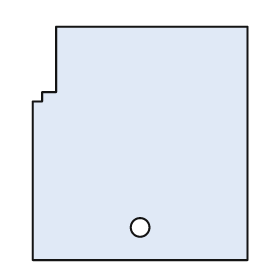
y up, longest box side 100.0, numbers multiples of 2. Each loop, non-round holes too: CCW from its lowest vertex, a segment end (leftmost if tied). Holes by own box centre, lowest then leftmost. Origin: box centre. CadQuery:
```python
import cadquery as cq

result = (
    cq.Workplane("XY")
    .moveTo(-46.0, -50.0)
    .lineTo(46.0, -50.0)
    .lineTo(46.0, 50.0)
    .lineTo(-36.0, 50.0)
    .lineTo(-36.0, 22.0)
    .lineTo(-42.0, 22.0)
    .lineTo(-42.0, 18.0)
    .lineTo(-46.0, 18.0)
    .close()
    .moveTo(0.0, -36.0)
    .circle(4.0)
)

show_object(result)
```